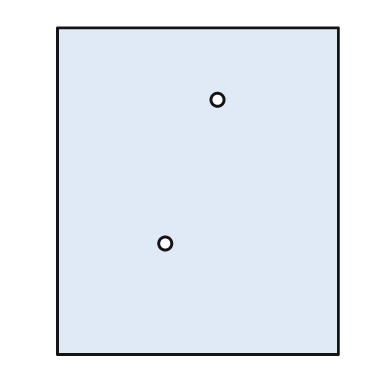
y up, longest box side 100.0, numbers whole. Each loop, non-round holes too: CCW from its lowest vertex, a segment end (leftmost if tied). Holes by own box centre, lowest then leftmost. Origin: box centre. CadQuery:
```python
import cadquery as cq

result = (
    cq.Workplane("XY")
    .moveTo(-43.0, -50.0)
    .lineTo(43.0, -50.0)
    .lineTo(43.0, 50.0)
    .lineTo(-43.0, 50.0)
    .close()
    .moveTo(-10.0, -16.0)
    .circle(2.0)
    .moveTo(6.0, 28.0)
    .circle(2.0)
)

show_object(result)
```